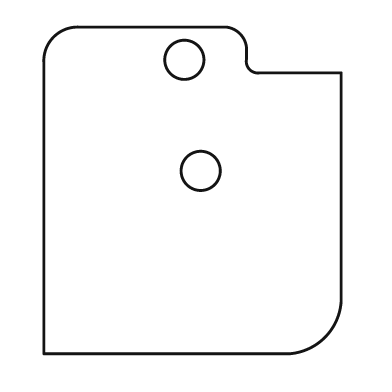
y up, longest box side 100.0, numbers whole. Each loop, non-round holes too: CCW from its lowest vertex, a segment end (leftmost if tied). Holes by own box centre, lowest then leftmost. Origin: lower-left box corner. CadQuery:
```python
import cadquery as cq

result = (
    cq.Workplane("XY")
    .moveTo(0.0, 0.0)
    .lineTo(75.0, 0.0)
    .threePointArc((86.0, 5.0), (91.0, 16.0))
    .lineTo(91.0, 86.0)
    .lineTo(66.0, 86.0)
    .threePointArc((63.0, 87.0), (62.0, 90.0))
    .lineTo(62.0, 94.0)
    .threePointArc((60.0, 98.0), (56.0, 100.0))
    .lineTo(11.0, 100.0)
    .threePointArc((3.0, 97.0), (0.0, 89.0))
    .close()
    .moveTo(48.0, 56.0)
    .circle(6.0)
    .moveTo(43.0, 90.0)
    .circle(6.0)
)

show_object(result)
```